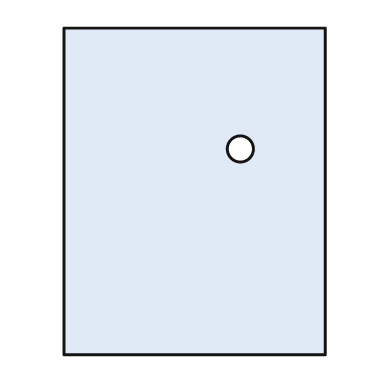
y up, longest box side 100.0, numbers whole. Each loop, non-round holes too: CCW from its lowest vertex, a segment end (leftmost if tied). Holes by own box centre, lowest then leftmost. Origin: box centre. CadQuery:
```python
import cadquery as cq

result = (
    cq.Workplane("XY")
    .moveTo(-40.0, -50.0)
    .lineTo(40.0, -50.0)
    .lineTo(40.0, 50.0)
    .lineTo(-40.0, 50.0)
    .close()
    .moveTo(14.0, 13.0)
    .circle(4.0)
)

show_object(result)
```